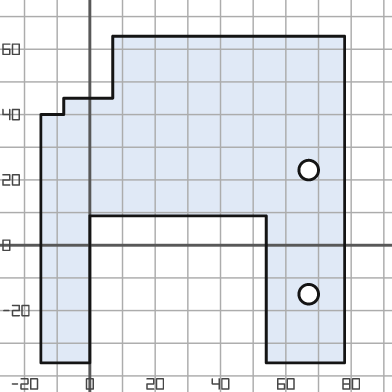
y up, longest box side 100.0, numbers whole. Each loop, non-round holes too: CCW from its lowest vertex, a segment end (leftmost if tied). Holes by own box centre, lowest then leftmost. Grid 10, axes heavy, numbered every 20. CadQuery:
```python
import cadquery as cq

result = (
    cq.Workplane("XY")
    .moveTo(-15.0, -36.0)
    .lineTo(0.0, -36.0)
    .lineTo(0.0, 9.0)
    .lineTo(54.0, 9.0)
    .lineTo(54.0, -36.0)
    .lineTo(78.0, -36.0)
    .lineTo(78.0, 64.0)
    .lineTo(7.0, 64.0)
    .lineTo(7.0, 45.0)
    .lineTo(-8.0, 45.0)
    .lineTo(-8.0, 40.0)
    .lineTo(-15.0, 40.0)
    .close()
    .moveTo(67.0, -15.0)
    .circle(3.0)
    .moveTo(67.0, 23.0)
    .circle(3.0)
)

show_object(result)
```